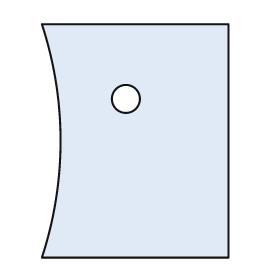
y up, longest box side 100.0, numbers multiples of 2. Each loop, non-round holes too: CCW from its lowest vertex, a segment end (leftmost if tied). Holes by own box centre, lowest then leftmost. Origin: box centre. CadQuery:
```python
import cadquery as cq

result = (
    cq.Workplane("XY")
    .moveTo(-40.0, -50.0)
    .lineTo(40.0, -50.0)
    .lineTo(40.0, 50.0)
    .lineTo(-40.0, 50.0)
    .threePointArc((-32.0, 0.0), (-40.0, -50.0))
    .close()
    .moveTo(-4.0, 18.0)
    .circle(6.0)
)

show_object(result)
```